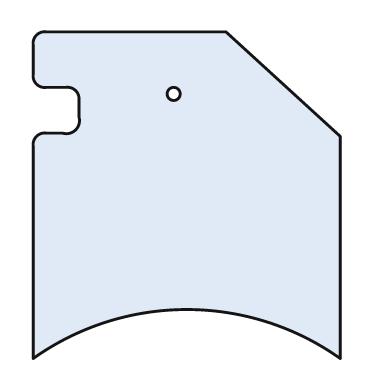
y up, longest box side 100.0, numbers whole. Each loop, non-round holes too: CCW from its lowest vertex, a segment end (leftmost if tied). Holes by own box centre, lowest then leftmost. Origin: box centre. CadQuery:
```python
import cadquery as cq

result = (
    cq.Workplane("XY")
    .moveTo(-47.0, -50.0)
    .threePointArc((0.0, -35.0), (47.0, -50.0))
    .lineTo(47.0, 18.0)
    .lineTo(12.0, 50.0)
    .lineTo(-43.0, 50.0)
    .threePointArc((-46.0, 49.0), (-47.0, 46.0))
    .lineTo(-47.0, 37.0)
    .threePointArc((-46.0, 34.0), (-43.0, 33.0))
    .lineTo(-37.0, 33.0)
    .threePointArc((-34.0, 32.0), (-33.0, 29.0))
    .lineTo(-33.0, 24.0)
    .threePointArc((-34.0, 20.0), (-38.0, 19.0))
    .lineTo(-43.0, 19.0)
    .threePointArc((-46.0, 18.0), (-47.0, 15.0))
    .close()
    .moveTo(-4.0, 31.0)
    .circle(2.0)
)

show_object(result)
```